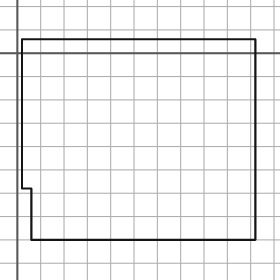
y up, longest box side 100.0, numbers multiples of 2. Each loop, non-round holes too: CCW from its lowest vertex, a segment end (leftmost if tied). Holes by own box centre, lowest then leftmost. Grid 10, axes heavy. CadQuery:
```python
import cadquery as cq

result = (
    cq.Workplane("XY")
    .moveTo(6.0, -80.0)
    .lineTo(102.0, -80.0)
    .lineTo(102.0, 6.0)
    .lineTo(2.0, 6.0)
    .lineTo(2.0, -58.0)
    .lineTo(6.0, -58.0)
    .close()
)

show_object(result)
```